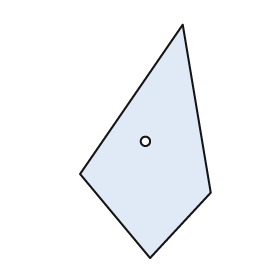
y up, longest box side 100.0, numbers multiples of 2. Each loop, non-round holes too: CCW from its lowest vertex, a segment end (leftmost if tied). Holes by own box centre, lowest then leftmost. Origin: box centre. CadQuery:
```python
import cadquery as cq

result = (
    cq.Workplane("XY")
    .moveTo(2.0, -50.0)
    .lineTo(28.0, -22.0)
    .lineTo(16.0, 50.0)
    .lineTo(-28.0, -14.0)
    .close()
    .moveTo(0.0, 0.0)
    .circle(2.0)
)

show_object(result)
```